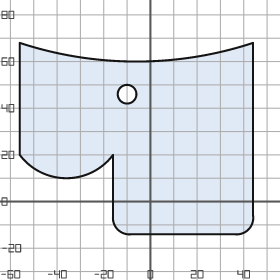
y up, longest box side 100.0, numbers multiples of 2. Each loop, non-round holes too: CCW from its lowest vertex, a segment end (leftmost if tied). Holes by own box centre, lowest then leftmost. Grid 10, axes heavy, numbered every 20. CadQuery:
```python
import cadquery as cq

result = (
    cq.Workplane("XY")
    .moveTo(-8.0, -14.0)
    .lineTo(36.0, -14.0)
    .threePointArc((42.0, -12.0), (44.0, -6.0))
    .lineTo(44.0, 68.0)
    .threePointArc((-6.0, 60.0), (-56.0, 68.0))
    .lineTo(-56.0, 20.0)
    .threePointArc((-36.0, 10.0), (-16.0, 20.0))
    .lineTo(-16.0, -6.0)
    .threePointArc((-14.0, -12.0), (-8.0, -14.0))
    .close()
    .moveTo(-10.0, 46.0)
    .circle(4.0)
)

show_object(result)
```